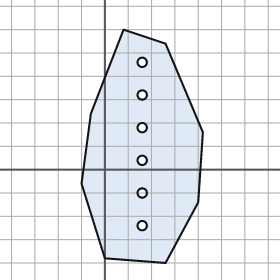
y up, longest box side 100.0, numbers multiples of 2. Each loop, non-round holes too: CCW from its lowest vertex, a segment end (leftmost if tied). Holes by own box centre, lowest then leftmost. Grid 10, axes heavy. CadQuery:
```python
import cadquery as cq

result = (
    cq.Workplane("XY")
    .moveTo(26.0, -40.0)
    .lineTo(40.0, -14.0)
    .lineTo(42.0, 16.0)
    .lineTo(26.0, 54.0)
    .lineTo(8.0, 60.0)
    .lineTo(-6.0, 24.0)
    .lineTo(-10.0, -6.0)
    .lineTo(0.0, -38.0)
    .close()
    .moveTo(16.0, -24.0)
    .circle(2.0)
    .moveTo(16.0, -10.0)
    .circle(2.0)
    .moveTo(16.0, 4.0)
    .circle(2.0)
    .moveTo(16.0, 18.0)
    .circle(2.0)
    .moveTo(16.0, 32.0)
    .circle(2.0)
    .moveTo(16.0, 46.0)
    .circle(2.0)
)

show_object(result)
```